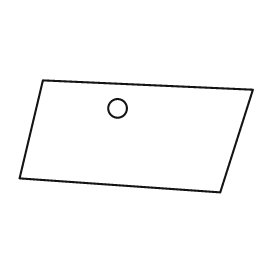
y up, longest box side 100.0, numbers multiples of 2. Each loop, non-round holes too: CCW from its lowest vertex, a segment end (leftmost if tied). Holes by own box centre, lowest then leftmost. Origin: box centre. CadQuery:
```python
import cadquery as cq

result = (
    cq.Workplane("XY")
    .moveTo(36.0, -24.0)
    .lineTo(50.0, 20.0)
    .lineTo(-40.0, 24.0)
    .lineTo(-50.0, -18.0)
    .close()
    .moveTo(-8.0, 12.0)
    .circle(4.0)
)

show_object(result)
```